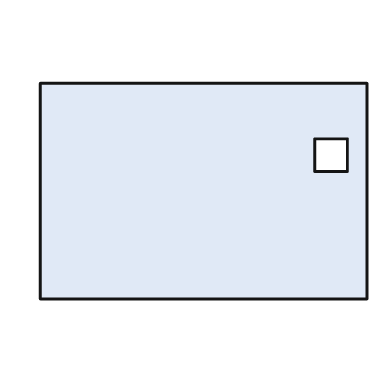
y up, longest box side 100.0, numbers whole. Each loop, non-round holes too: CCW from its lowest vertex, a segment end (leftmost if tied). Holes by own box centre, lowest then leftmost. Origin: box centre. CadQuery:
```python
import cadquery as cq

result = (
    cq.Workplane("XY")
    .moveTo(-50.0, -33.0)
    .lineTo(50.0, -33.0)
    .lineTo(50.0, 33.0)
    .lineTo(-50.0, 33.0)
    .close()
    .moveTo(34.0, 6.0)
    .lineTo(44.0, 6.0)
    .lineTo(44.0, 16.0)
    .lineTo(34.0, 16.0)
    .close()
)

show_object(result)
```